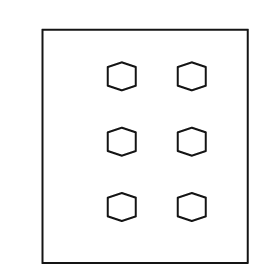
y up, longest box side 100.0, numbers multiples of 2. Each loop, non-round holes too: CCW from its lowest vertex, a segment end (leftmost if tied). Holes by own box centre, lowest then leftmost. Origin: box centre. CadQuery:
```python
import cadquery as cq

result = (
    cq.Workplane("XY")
    .moveTo(-44.0, -50.0)
    .lineTo(44.0, -50.0)
    .lineTo(44.0, 50.0)
    .lineTo(-44.0, 50.0)
    .close()
    .moveTo(-10.0, -32.0)
    .lineTo(-4.0, -30.0)
    .lineTo(-4.0, -22.0)
    .lineTo(-10.0, -20.0)
    .lineTo(-16.0, -22.0)
    .lineTo(-16.0, -30.0)
    .close()
    .moveTo(20.0, -32.0)
    .lineTo(26.0, -30.0)
    .lineTo(26.0, -22.0)
    .lineTo(20.0, -20.0)
    .lineTo(14.0, -22.0)
    .lineTo(14.0, -30.0)
    .close()
    .moveTo(-10.0, -4.0)
    .lineTo(-4.0, -2.0)
    .lineTo(-4.0, 6.0)
    .lineTo(-10.0, 8.0)
    .lineTo(-16.0, 6.0)
    .lineTo(-16.0, -2.0)
    .close()
    .moveTo(20.0, -4.0)
    .lineTo(26.0, -2.0)
    .lineTo(26.0, 6.0)
    .lineTo(20.0, 8.0)
    .lineTo(14.0, 6.0)
    .lineTo(14.0, -2.0)
    .close()
    .moveTo(-10.0, 24.0)
    .lineTo(-4.0, 26.0)
    .lineTo(-4.0, 34.0)
    .lineTo(-10.0, 36.0)
    .lineTo(-16.0, 34.0)
    .lineTo(-16.0, 26.0)
    .close()
    .moveTo(20.0, 24.0)
    .lineTo(26.0, 26.0)
    .lineTo(26.0, 34.0)
    .lineTo(20.0, 36.0)
    .lineTo(14.0, 34.0)
    .lineTo(14.0, 26.0)
    .close()
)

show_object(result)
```